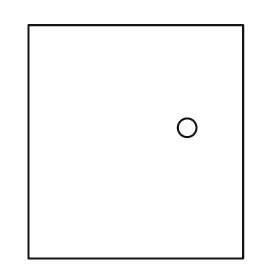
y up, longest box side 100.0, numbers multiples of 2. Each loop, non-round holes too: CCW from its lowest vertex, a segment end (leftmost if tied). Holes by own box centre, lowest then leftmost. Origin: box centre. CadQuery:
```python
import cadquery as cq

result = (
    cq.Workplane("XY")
    .moveTo(-46.0, -50.0)
    .lineTo(46.0, -50.0)
    .lineTo(46.0, 50.0)
    .lineTo(-46.0, 50.0)
    .close()
    .moveTo(22.0, 6.0)
    .circle(4.0)
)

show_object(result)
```